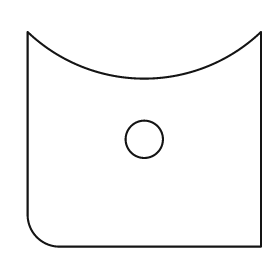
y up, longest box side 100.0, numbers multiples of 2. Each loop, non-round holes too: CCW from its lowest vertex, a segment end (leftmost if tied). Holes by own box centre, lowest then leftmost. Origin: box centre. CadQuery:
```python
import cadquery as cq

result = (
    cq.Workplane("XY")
    .moveTo(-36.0, -46.0)
    .lineTo(50.0, -46.0)
    .lineTo(50.0, 46.0)
    .threePointArc((0.0, 26.0), (-50.0, 46.0))
    .lineTo(-50.0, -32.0)
    .threePointArc((-46.0, -42.0), (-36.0, -46.0))
    .close()
    .moveTo(0.0, 0.0)
    .circle(8.0)
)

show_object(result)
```